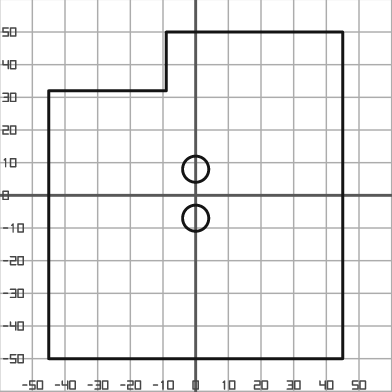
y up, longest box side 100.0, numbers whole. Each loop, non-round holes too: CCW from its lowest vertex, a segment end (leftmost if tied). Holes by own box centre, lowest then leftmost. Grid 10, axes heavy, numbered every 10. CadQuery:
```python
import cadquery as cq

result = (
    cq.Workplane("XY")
    .moveTo(-45.0, -50.0)
    .lineTo(45.0, -50.0)
    .lineTo(45.0, 50.0)
    .lineTo(-9.0, 50.0)
    .lineTo(-9.0, 32.0)
    .lineTo(-45.0, 32.0)
    .close()
    .moveTo(0.0, -7.0)
    .circle(4.0)
    .moveTo(0.0, 8.0)
    .circle(4.0)
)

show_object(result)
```